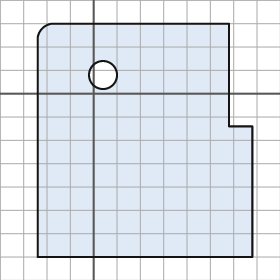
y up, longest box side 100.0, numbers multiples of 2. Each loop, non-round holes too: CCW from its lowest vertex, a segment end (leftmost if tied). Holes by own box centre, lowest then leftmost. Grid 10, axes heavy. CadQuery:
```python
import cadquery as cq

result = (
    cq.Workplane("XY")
    .moveTo(-24.0, -70.0)
    .lineTo(68.0, -70.0)
    .lineTo(68.0, -14.0)
    .lineTo(58.0, -14.0)
    .lineTo(58.0, 30.0)
    .lineTo(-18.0, 30.0)
    .threePointArc((-22.0, 28.0), (-24.0, 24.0))
    .close()
    .moveTo(4.0, 8.0)
    .circle(6.0)
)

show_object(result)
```